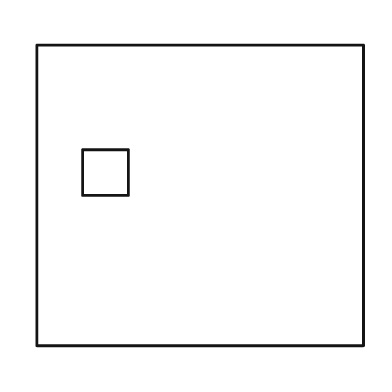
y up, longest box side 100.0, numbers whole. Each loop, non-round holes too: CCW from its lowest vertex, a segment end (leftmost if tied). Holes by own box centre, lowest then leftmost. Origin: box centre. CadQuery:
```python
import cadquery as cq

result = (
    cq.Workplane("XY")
    .moveTo(-50.0, -46.0)
    .lineTo(50.0, -46.0)
    .lineTo(50.0, 46.0)
    .lineTo(-50.0, 46.0)
    .close()
    .moveTo(-36.0, 0.0)
    .lineTo(-22.0, 0.0)
    .lineTo(-22.0, 14.0)
    .lineTo(-36.0, 14.0)
    .close()
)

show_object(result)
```